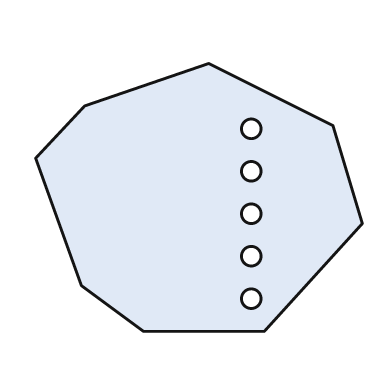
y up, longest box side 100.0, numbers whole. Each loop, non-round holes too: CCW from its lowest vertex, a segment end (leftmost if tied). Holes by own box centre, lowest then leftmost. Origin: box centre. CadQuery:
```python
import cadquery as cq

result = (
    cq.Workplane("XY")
    .moveTo(-17.0, -41.0)
    .lineTo(20.0, -41.0)
    .lineTo(50.0, -8.0)
    .lineTo(41.0, 22.0)
    .lineTo(3.0, 41.0)
    .lineTo(-35.0, 28.0)
    .lineTo(-50.0, 12.0)
    .lineTo(-36.0, -27.0)
    .close()
    .moveTo(16.0, -31.0)
    .circle(3.0)
    .moveTo(16.0, -18.0)
    .circle(3.0)
    .moveTo(16.0, -5.0)
    .circle(3.0)
    .moveTo(16.0, 8.0)
    .circle(3.0)
    .moveTo(16.0, 21.0)
    .circle(3.0)
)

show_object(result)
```